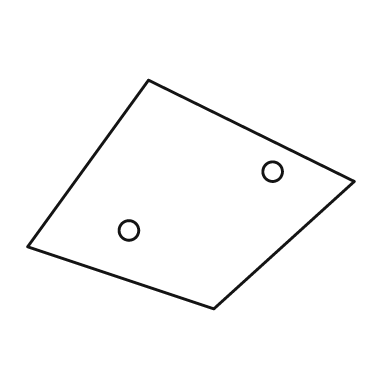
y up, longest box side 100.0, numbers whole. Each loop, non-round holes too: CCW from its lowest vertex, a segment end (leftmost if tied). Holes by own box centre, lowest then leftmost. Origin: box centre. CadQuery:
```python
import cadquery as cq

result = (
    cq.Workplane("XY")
    .moveTo(7.0, -35.0)
    .lineTo(50.0, 4.0)
    .lineTo(-13.0, 35.0)
    .lineTo(-50.0, -16.0)
    .close()
    .moveTo(-19.0, -11.0)
    .circle(3.0)
    .moveTo(25.0, 7.0)
    .circle(3.0)
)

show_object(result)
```